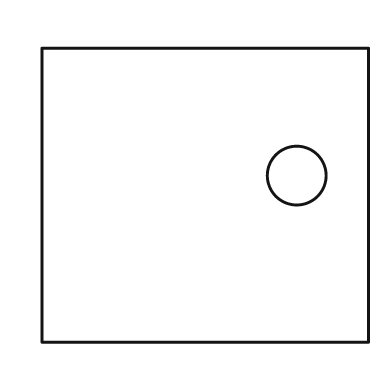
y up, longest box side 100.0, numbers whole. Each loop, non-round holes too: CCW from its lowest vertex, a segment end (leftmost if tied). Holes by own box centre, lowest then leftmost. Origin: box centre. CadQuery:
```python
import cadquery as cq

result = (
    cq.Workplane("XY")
    .moveTo(-50.0, -45.0)
    .lineTo(50.0, -45.0)
    .lineTo(50.0, 45.0)
    .lineTo(-50.0, 45.0)
    .close()
    .moveTo(28.0, 6.0)
    .circle(9.0)
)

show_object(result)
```